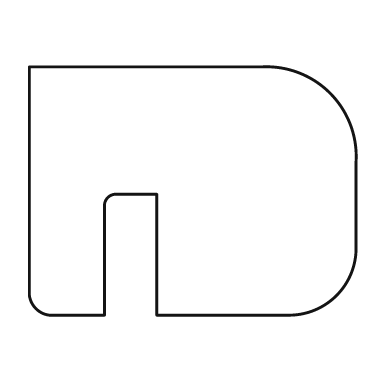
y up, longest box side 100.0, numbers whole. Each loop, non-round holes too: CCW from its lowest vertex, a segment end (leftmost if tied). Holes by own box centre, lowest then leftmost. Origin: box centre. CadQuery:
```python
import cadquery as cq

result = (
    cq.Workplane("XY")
    .moveTo(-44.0, -38.0)
    .lineTo(-27.0, -38.0)
    .lineTo(-27.0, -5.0)
    .threePointArc((-26.0, -2.0), (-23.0, -1.0))
    .lineTo(-11.0, -1.0)
    .lineTo(-11.0, -38.0)
    .lineTo(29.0, -38.0)
    .threePointArc((44.0, -32.0), (50.0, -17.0))
    .lineTo(50.0, 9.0)
    .threePointArc((42.0, 30.0), (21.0, 38.0))
    .lineTo(-50.0, 38.0)
    .lineTo(-50.0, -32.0)
    .threePointArc((-48.0, -36.0), (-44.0, -38.0))
    .close()
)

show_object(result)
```